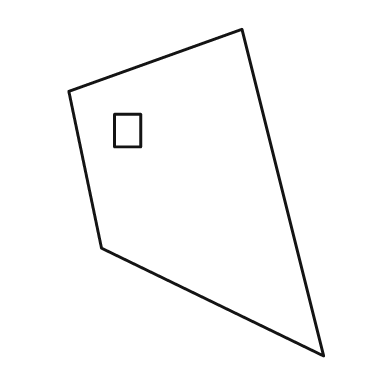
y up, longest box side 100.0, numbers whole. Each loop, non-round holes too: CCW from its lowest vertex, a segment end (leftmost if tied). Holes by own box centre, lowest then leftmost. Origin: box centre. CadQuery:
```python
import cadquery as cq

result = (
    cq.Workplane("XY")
    .moveTo(39.0, -50.0)
    .lineTo(14.0, 50.0)
    .lineTo(-39.0, 31.0)
    .lineTo(-29.0, -17.0)
    .close()
    .moveTo(-25.0, 14.0)
    .lineTo(-17.0, 14.0)
    .lineTo(-17.0, 24.0)
    .lineTo(-25.0, 24.0)
    .close()
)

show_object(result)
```